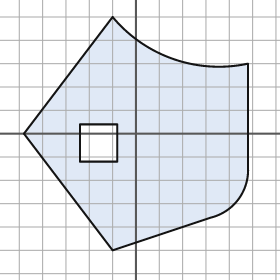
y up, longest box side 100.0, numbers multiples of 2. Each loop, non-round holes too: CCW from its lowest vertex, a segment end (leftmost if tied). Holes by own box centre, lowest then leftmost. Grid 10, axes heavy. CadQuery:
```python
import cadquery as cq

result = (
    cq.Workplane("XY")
    .moveTo(-10.0, -50.0)
    .lineTo(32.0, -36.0)
    .threePointArc((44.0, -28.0), (48.0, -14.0))
    .lineTo(48.0, 30.0)
    .threePointArc((16.0, 32.0), (-10.0, 50.0))
    .lineTo(-48.0, 0.0)
    .close()
    .moveTo(-24.0, -12.0)
    .lineTo(-8.0, -12.0)
    .lineTo(-8.0, 4.0)
    .lineTo(-24.0, 4.0)
    .close()
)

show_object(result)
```